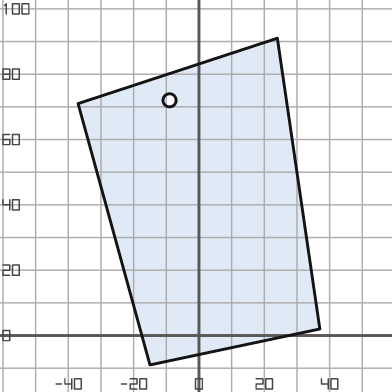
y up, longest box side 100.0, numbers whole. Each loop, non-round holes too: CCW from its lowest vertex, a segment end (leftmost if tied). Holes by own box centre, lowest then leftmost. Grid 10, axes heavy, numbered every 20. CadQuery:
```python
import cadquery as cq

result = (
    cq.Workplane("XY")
    .moveTo(-15.0, -9.0)
    .lineTo(37.0, 2.0)
    .lineTo(24.0, 91.0)
    .lineTo(-37.0, 71.0)
    .close()
    .moveTo(-9.0, 72.0)
    .circle(2.0)
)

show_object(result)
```